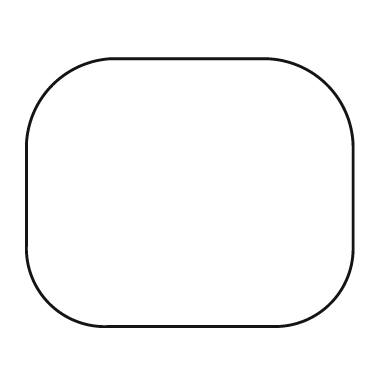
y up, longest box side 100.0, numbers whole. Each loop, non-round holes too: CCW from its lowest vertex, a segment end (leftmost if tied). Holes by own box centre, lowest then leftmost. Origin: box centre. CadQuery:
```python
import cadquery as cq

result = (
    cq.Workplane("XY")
    .moveTo(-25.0, -41.0)
    .lineTo(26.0, -41.0)
    .threePointArc((43.0, -34.0), (50.0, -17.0))
    .lineTo(50.0, 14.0)
    .threePointArc((42.0, 33.0), (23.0, 41.0))
    .lineTo(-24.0, 41.0)
    .threePointArc((-42.0, 33.0), (-50.0, 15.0))
    .lineTo(-50.0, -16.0)
    .threePointArc((-43.0, -34.0), (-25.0, -41.0))
    .close()
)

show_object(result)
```